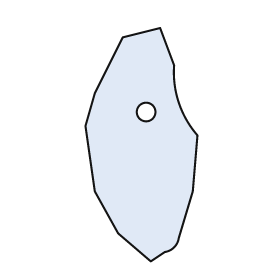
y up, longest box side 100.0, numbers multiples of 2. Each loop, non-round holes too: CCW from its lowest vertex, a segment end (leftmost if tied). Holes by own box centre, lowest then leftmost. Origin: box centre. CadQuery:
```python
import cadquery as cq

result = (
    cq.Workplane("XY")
    .moveTo(4.0, -50.0)
    .lineTo(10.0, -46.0)
    .threePointArc((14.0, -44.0), (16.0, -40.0))
    .lineTo(22.0, -20.0)
    .lineTo(24.0, 4.0)
    .threePointArc((16.0, 18.0), (14.0, 34.0))
    .lineTo(8.0, 50.0)
    .lineTo(-8.0, 46.0)
    .lineTo(-20.0, 22.0)
    .lineTo(-24.0, 8.0)
    .lineTo(-20.0, -20.0)
    .lineTo(-10.0, -38.0)
    .close()
    .moveTo(2.0, 14.0)
    .circle(4.0)
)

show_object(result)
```